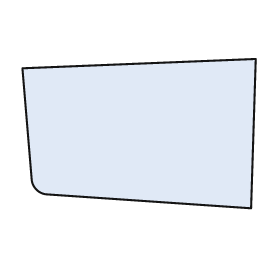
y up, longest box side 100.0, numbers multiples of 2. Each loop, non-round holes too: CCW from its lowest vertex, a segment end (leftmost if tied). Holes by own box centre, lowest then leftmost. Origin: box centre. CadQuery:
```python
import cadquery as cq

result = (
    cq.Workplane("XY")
    .moveTo(48.0, -32.0)
    .lineTo(50.0, 32.0)
    .lineTo(-50.0, 28.0)
    .lineTo(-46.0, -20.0)
    .threePointArc((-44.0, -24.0), (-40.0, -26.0))
    .close()
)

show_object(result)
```